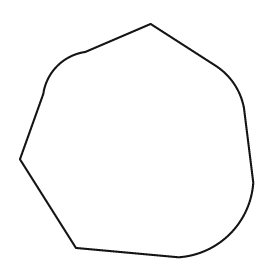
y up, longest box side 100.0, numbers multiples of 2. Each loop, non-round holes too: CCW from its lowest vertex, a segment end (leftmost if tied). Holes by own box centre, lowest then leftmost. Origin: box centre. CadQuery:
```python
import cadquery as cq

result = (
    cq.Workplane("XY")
    .moveTo(18.0, -50.0)
    .threePointArc((40.0, -40.0), (50.0, -18.0))
    .lineTo(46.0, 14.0)
    .threePointArc((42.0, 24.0), (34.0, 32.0))
    .lineTo(6.0, 50.0)
    .lineTo(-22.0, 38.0)
    .threePointArc((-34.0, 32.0), (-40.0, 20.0))
    .lineTo(-50.0, -8.0)
    .lineTo(-26.0, -46.0)
    .close()
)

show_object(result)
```